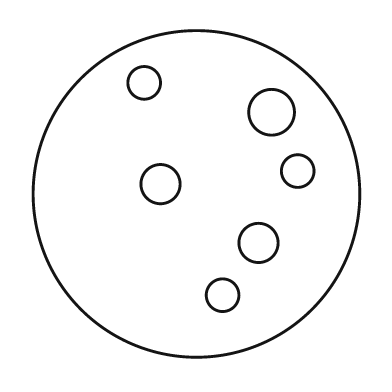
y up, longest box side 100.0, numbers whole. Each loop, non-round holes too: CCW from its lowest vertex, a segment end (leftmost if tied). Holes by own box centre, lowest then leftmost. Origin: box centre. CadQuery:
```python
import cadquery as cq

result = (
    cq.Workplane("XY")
    .moveTo(0.0, 0.0)
    .circle(50.0)
    .moveTo(8.0, -31.0)
    .circle(5.0)
    .moveTo(19.0, -15.0)
    .circle(6.0)
    .moveTo(-11.0, 3.0)
    .circle(6.0)
    .moveTo(31.0, 7.0)
    .circle(5.0)
    .moveTo(23.0, 25.0)
    .circle(7.0)
    .moveTo(-16.0, 34.0)
    .circle(5.0)
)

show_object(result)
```